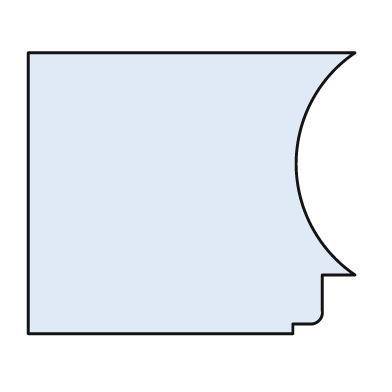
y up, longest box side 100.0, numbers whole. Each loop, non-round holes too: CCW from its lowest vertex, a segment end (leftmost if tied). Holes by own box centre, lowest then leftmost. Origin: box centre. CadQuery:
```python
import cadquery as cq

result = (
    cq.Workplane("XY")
    .moveTo(-50.0, -43.0)
    .lineTo(31.0, -43.0)
    .lineTo(31.0, -40.0)
    .lineTo(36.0, -40.0)
    .threePointArc((39.0, -39.0), (40.0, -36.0))
    .lineTo(40.0, -25.0)
    .lineTo(50.0, -25.0)
    .threePointArc((32.0, 9.0), (50.0, 43.0))
    .lineTo(-50.0, 43.0)
    .close()
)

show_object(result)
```